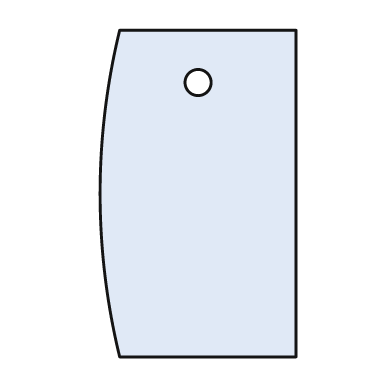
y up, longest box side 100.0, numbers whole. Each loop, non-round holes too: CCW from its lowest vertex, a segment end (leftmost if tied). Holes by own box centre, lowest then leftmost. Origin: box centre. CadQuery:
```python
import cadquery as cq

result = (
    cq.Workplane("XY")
    .moveTo(-24.0, -50.0)
    .lineTo(30.0, -50.0)
    .lineTo(30.0, 50.0)
    .lineTo(-24.0, 50.0)
    .threePointArc((-30.0, 0.0), (-24.0, -50.0))
    .close()
    .moveTo(0.0, 34.0)
    .circle(4.0)
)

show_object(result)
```